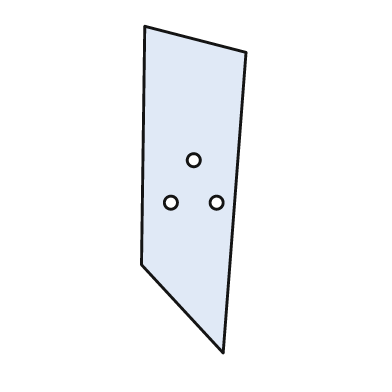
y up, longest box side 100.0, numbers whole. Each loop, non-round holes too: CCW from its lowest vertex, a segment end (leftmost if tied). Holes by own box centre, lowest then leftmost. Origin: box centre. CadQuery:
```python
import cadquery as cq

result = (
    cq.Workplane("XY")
    .moveTo(9.0, -50.0)
    .lineTo(16.0, 42.0)
    .lineTo(-15.0, 50.0)
    .lineTo(-16.0, -23.0)
    .close()
    .moveTo(-7.0, -4.0)
    .circle(2.0)
    .moveTo(7.0, -4.0)
    .circle(2.0)
    .moveTo(0.0, 9.0)
    .circle(2.0)
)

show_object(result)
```